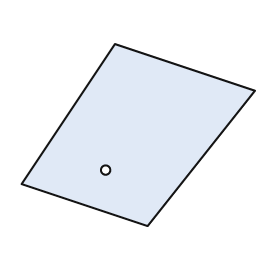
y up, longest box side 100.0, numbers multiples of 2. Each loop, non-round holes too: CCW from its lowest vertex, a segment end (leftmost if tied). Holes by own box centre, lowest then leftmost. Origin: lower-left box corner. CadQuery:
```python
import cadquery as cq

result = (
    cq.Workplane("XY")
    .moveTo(54.0, 0.0)
    .lineTo(100.0, 58.0)
    .lineTo(40.0, 78.0)
    .lineTo(0.0, 18.0)
    .close()
    .moveTo(36.0, 24.0)
    .circle(2.0)
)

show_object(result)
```